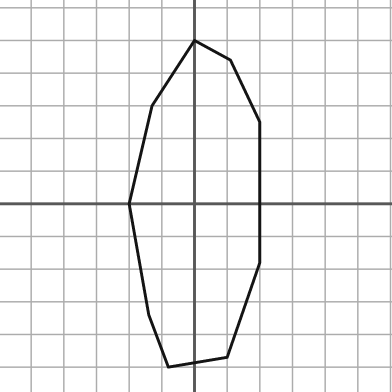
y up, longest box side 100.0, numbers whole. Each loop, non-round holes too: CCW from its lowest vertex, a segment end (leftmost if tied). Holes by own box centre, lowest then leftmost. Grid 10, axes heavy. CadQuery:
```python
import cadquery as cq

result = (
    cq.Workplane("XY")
    .moveTo(-8.0, -50.0)
    .lineTo(10.0, -47.0)
    .lineTo(20.0, -18.0)
    .lineTo(20.0, 25.0)
    .lineTo(11.0, 44.0)
    .lineTo(0.0, 50.0)
    .lineTo(-13.0, 30.0)
    .lineTo(-20.0, 0.0)
    .lineTo(-14.0, -34.0)
    .close()
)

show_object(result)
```